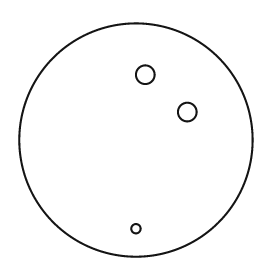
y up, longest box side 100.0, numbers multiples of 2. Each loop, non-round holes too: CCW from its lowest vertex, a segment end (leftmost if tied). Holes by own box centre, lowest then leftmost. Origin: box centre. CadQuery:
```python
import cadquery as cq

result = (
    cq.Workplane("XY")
    .moveTo(0.0, 0.0)
    .circle(50.0)
    .moveTo(0.0, -38.0)
    .circle(2.0)
    .moveTo(22.0, 12.0)
    .circle(4.0)
    .moveTo(4.0, 28.0)
    .circle(4.0)
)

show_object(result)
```